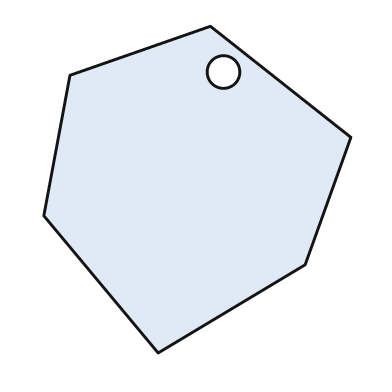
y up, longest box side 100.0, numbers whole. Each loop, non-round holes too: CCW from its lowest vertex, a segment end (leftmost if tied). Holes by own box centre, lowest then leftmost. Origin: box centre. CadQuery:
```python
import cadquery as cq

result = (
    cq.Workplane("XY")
    .moveTo(-12.0, -50.0)
    .lineTo(33.0, -23.0)
    .lineTo(47.0, 16.0)
    .lineTo(4.0, 50.0)
    .lineTo(-39.0, 35.0)
    .lineTo(-47.0, -8.0)
    .close()
    .moveTo(8.0, 36.0)
    .circle(5.0)
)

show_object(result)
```